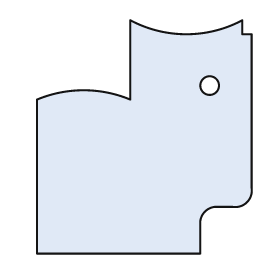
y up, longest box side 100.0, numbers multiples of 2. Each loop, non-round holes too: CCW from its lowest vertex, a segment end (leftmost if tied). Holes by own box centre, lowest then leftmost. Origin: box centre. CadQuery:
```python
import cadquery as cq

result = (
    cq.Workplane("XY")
    .moveTo(-46.0, -50.0)
    .lineTo(24.0, -50.0)
    .lineTo(24.0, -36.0)
    .threePointArc((26.0, -32.0), (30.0, -30.0))
    .lineTo(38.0, -30.0)
    .threePointArc((44.0, -28.0), (46.0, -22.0))
    .lineTo(46.0, 44.0)
    .lineTo(42.0, 44.0)
    .lineTo(42.0, 50.0)
    .threePointArc((18.0, 44.0), (-6.0, 50.0))
    .lineTo(-6.0, 16.0)
    .threePointArc((-26.0, 20.0), (-46.0, 16.0))
    .close()
    .moveTo(28.0, 22.0)
    .circle(4.0)
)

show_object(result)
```